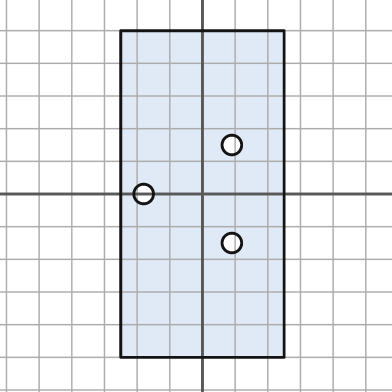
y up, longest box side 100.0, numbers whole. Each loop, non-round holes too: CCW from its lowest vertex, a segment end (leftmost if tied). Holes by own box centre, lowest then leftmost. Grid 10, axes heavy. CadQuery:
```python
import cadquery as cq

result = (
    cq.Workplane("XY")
    .moveTo(-25.0, -50.0)
    .lineTo(25.0, -50.0)
    .lineTo(25.0, 50.0)
    .lineTo(-25.0, 50.0)
    .close()
    .moveTo(9.0, -15.0)
    .circle(3.0)
    .moveTo(-18.0, 0.0)
    .circle(3.0)
    .moveTo(9.0, 15.0)
    .circle(3.0)
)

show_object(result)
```